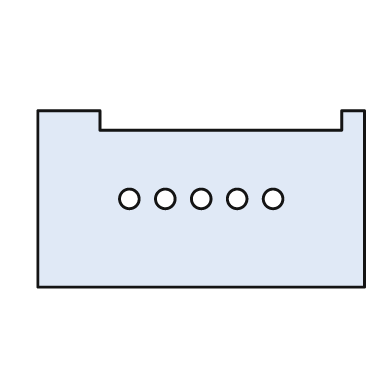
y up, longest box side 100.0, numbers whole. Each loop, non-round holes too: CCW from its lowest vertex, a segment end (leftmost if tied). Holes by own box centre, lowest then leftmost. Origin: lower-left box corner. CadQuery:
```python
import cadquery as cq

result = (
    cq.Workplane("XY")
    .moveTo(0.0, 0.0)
    .lineTo(100.0, 0.0)
    .lineTo(100.0, 54.0)
    .lineTo(93.0, 54.0)
    .lineTo(93.0, 48.0)
    .lineTo(19.0, 48.0)
    .lineTo(19.0, 54.0)
    .lineTo(0.0, 54.0)
    .close()
    .moveTo(28.0, 27.0)
    .circle(3.0)
    .moveTo(39.0, 27.0)
    .circle(3.0)
    .moveTo(50.0, 27.0)
    .circle(3.0)
    .moveTo(61.0, 27.0)
    .circle(3.0)
    .moveTo(72.0, 27.0)
    .circle(3.0)
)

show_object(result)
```